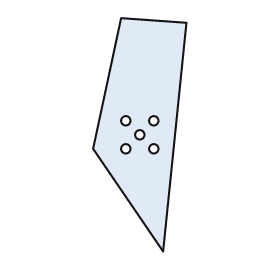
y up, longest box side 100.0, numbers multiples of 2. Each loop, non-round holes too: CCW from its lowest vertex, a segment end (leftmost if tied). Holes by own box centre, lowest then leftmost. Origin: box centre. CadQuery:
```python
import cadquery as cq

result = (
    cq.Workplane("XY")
    .moveTo(10.0, -50.0)
    .lineTo(20.0, 48.0)
    .lineTo(-8.0, 50.0)
    .lineTo(-20.0, -6.0)
    .close()
    .moveTo(-6.0, -6.0)
    .circle(2.0)
    .moveTo(6.0, -6.0)
    .circle(2.0)
    .moveTo(0.0, 0.0)
    .circle(2.0)
    .moveTo(-6.0, 6.0)
    .circle(2.0)
    .moveTo(6.0, 6.0)
    .circle(2.0)
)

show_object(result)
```